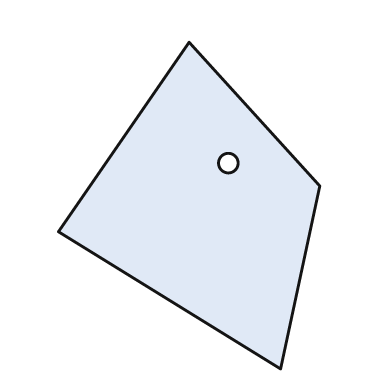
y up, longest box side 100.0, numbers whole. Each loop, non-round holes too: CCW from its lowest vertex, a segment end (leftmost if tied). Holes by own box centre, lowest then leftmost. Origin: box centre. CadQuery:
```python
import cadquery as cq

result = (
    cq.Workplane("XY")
    .moveTo(28.0, -50.0)
    .lineTo(40.0, 6.0)
    .lineTo(0.0, 50.0)
    .lineTo(-40.0, -8.0)
    .close()
    .moveTo(12.0, 13.0)
    .circle(3.0)
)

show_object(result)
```